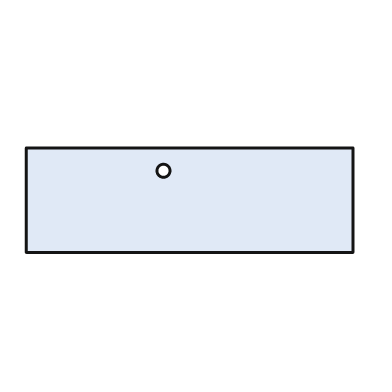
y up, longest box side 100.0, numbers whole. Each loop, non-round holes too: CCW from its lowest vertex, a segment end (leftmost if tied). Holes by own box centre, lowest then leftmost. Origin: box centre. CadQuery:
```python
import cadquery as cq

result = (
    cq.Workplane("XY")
    .moveTo(-50.0, -16.0)
    .lineTo(50.0, -16.0)
    .lineTo(50.0, 16.0)
    .lineTo(-50.0, 16.0)
    .close()
    .moveTo(-8.0, 9.0)
    .circle(2.0)
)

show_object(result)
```